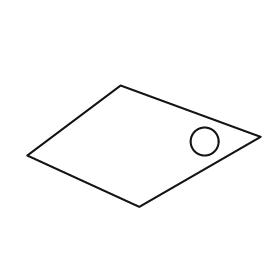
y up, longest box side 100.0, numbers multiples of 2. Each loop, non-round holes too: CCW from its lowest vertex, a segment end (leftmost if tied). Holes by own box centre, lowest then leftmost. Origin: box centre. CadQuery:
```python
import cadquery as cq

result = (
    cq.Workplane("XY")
    .moveTo(-2.0, -26.0)
    .lineTo(50.0, 4.0)
    .lineTo(-10.0, 26.0)
    .lineTo(-50.0, -4.0)
    .close()
    .moveTo(26.0, 2.0)
    .circle(6.0)
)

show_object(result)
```